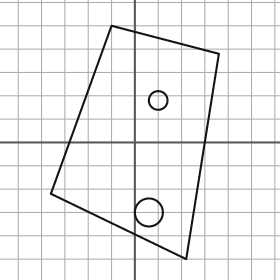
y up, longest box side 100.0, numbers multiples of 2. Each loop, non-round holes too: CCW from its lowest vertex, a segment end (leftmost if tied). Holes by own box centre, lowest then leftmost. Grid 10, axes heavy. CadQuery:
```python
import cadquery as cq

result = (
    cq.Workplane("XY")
    .moveTo(22.0, -50.0)
    .lineTo(36.0, 38.0)
    .lineTo(-10.0, 50.0)
    .lineTo(-36.0, -22.0)
    .close()
    .moveTo(6.0, -30.0)
    .circle(6.0)
    .moveTo(10.0, 18.0)
    .circle(4.0)
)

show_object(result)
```